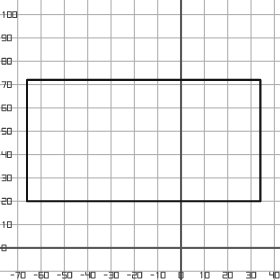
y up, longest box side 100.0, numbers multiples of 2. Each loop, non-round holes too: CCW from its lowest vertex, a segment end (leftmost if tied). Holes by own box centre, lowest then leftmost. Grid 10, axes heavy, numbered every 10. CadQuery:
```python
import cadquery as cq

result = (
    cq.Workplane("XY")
    .moveTo(-66.0, 20.0)
    .lineTo(34.0, 20.0)
    .lineTo(34.0, 72.0)
    .lineTo(-66.0, 72.0)
    .close()
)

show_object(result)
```